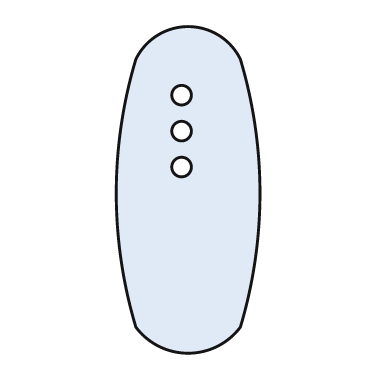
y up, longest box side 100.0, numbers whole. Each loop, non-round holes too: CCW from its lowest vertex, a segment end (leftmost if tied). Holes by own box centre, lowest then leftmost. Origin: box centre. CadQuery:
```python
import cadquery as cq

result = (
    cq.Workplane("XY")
    .moveTo(-16.0, -42.0)
    .threePointArc((0.0, -50.0), (16.0, -42.0))
    .threePointArc((22.0, -1.0), (16.0, 40.0))
    .threePointArc((0.0, 50.0), (-16.0, 40.0))
    .threePointArc((-22.0, -1.0), (-16.0, -42.0))
    .close()
    .moveTo(-2.0, 7.0)
    .circle(3.0)
    .moveTo(-2.0, 18.0)
    .circle(3.0)
    .moveTo(-2.0, 29.0)
    .circle(3.0)
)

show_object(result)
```